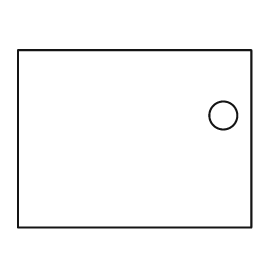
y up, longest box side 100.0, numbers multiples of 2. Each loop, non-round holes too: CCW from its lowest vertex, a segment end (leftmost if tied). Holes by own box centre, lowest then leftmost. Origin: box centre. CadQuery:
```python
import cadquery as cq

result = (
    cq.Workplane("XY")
    .moveTo(-50.0, -38.0)
    .lineTo(50.0, -38.0)
    .lineTo(50.0, 38.0)
    .lineTo(-50.0, 38.0)
    .close()
    .moveTo(38.0, 10.0)
    .circle(6.0)
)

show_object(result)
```